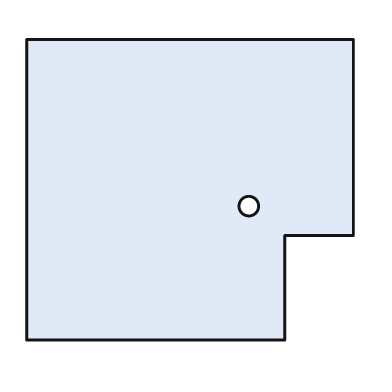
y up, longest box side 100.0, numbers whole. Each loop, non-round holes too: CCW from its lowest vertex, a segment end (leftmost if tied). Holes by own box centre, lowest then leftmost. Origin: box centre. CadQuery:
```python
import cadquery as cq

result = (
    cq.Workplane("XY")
    .moveTo(-50.0, -46.0)
    .lineTo(29.0, -46.0)
    .lineTo(29.0, -14.0)
    .lineTo(50.0, -14.0)
    .lineTo(50.0, 46.0)
    .lineTo(-50.0, 46.0)
    .close()
    .moveTo(18.0, -5.0)
    .circle(3.0)
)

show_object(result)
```